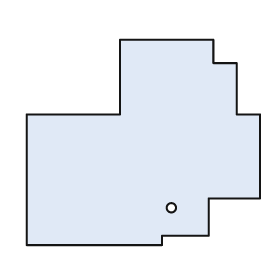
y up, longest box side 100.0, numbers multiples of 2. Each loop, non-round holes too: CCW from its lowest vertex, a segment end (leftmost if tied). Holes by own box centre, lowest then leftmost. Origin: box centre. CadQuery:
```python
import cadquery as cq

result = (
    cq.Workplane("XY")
    .moveTo(-50.0, -44.0)
    .lineTo(8.0, -44.0)
    .lineTo(8.0, -40.0)
    .lineTo(28.0, -40.0)
    .lineTo(28.0, -24.0)
    .lineTo(50.0, -24.0)
    .lineTo(50.0, 12.0)
    .lineTo(40.0, 12.0)
    .lineTo(40.0, 34.0)
    .lineTo(30.0, 34.0)
    .lineTo(30.0, 44.0)
    .lineTo(-10.0, 44.0)
    .lineTo(-10.0, 12.0)
    .lineTo(-50.0, 12.0)
    .close()
    .moveTo(12.0, -28.0)
    .circle(2.0)
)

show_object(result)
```